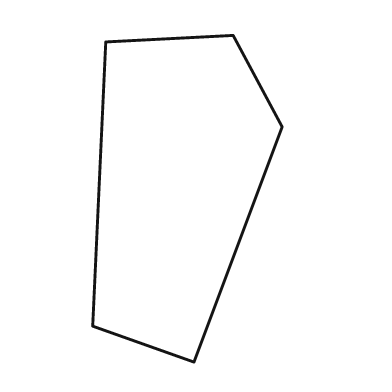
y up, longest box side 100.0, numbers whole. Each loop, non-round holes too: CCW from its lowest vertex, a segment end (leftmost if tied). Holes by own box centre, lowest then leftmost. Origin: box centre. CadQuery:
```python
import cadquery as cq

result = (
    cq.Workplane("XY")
    .moveTo(2.0, -50.0)
    .lineTo(29.0, 22.0)
    .lineTo(14.0, 50.0)
    .lineTo(-25.0, 48.0)
    .lineTo(-29.0, -39.0)
    .close()
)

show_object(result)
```